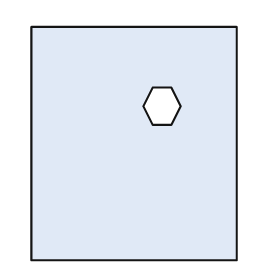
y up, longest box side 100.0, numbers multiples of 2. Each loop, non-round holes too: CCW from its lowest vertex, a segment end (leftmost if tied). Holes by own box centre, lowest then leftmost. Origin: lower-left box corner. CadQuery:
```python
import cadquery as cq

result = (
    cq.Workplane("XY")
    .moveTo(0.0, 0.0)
    .lineTo(88.0, 0.0)
    .lineTo(88.0, 100.0)
    .lineTo(0.0, 100.0)
    .close()
    .moveTo(52.0, 58.0)
    .lineTo(60.0, 58.0)
    .lineTo(64.0, 66.0)
    .lineTo(60.0, 74.0)
    .lineTo(52.0, 74.0)
    .lineTo(48.0, 66.0)
    .close()
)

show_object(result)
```